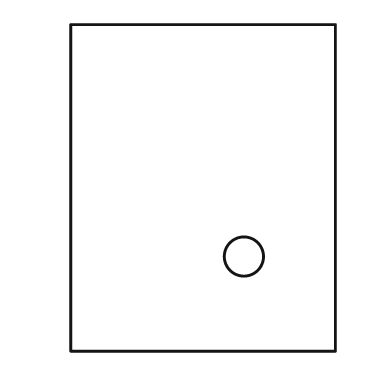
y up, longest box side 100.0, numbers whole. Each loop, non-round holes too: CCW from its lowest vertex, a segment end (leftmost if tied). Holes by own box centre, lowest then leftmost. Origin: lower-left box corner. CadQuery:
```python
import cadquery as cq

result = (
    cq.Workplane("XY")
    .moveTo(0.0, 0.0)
    .lineTo(81.0, 0.0)
    .lineTo(81.0, 100.0)
    .lineTo(0.0, 100.0)
    .close()
    .moveTo(53.0, 29.0)
    .circle(6.0)
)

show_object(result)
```